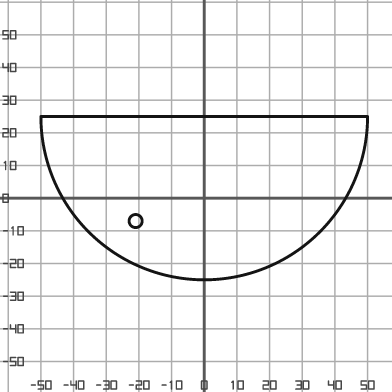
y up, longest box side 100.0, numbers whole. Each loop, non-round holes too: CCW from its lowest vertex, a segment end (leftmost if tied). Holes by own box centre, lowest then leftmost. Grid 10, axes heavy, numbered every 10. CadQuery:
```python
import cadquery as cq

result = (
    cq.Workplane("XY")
    .moveTo(-50.0, 25.0)
    .threePointArc((0.0, -25.0), (50.0, 25.0))
    .close()
    .moveTo(-21.0, -7.0)
    .circle(2.0)
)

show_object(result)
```